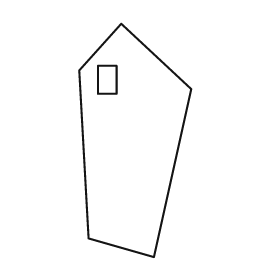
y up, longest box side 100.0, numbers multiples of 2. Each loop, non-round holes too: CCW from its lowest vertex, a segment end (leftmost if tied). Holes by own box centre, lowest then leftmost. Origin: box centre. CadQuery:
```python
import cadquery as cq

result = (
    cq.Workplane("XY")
    .moveTo(8.0, -50.0)
    .lineTo(24.0, 22.0)
    .lineTo(-6.0, 50.0)
    .lineTo(-24.0, 30.0)
    .lineTo(-20.0, -42.0)
    .close()
    .moveTo(-16.0, 20.0)
    .lineTo(-8.0, 20.0)
    .lineTo(-8.0, 32.0)
    .lineTo(-16.0, 32.0)
    .close()
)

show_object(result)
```